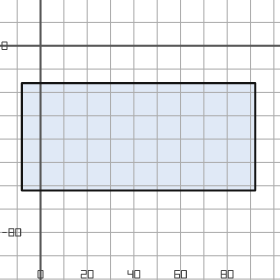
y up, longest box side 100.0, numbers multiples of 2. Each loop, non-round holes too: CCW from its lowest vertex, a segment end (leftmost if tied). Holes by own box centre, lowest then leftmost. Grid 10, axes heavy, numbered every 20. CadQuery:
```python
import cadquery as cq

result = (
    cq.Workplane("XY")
    .moveTo(-8.0, -62.0)
    .lineTo(92.0, -62.0)
    .lineTo(92.0, -16.0)
    .lineTo(-8.0, -16.0)
    .close()
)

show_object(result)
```